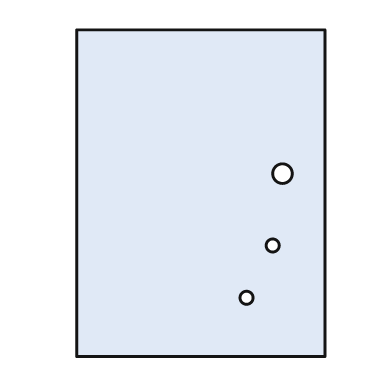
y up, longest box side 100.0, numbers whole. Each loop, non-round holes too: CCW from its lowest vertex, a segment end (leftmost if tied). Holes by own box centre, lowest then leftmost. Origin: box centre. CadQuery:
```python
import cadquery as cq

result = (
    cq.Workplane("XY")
    .moveTo(-38.0, -50.0)
    .lineTo(38.0, -50.0)
    .lineTo(38.0, 50.0)
    .lineTo(-38.0, 50.0)
    .close()
    .moveTo(14.0, -32.0)
    .circle(2.0)
    .moveTo(22.0, -16.0)
    .circle(2.0)
    .moveTo(25.0, 6.0)
    .circle(3.0)
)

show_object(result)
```